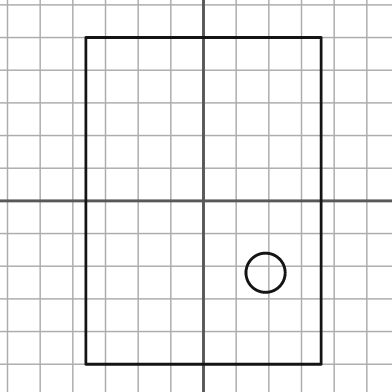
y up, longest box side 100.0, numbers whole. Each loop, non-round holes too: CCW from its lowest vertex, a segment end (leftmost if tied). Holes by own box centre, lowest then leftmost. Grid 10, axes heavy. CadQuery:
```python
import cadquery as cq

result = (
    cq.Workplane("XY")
    .moveTo(-36.0, -50.0)
    .lineTo(36.0, -50.0)
    .lineTo(36.0, 50.0)
    .lineTo(-36.0, 50.0)
    .close()
    .moveTo(19.0, -22.0)
    .circle(6.0)
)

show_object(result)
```